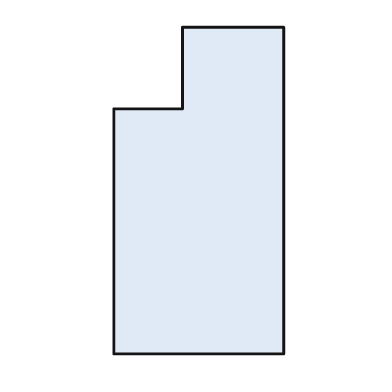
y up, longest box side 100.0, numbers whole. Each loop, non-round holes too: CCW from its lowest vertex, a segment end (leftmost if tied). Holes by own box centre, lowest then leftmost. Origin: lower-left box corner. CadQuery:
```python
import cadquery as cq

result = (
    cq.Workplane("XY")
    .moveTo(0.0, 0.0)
    .lineTo(52.0, 0.0)
    .lineTo(52.0, 100.0)
    .lineTo(21.0, 100.0)
    .lineTo(21.0, 75.0)
    .lineTo(0.0, 75.0)
    .close()
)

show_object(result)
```